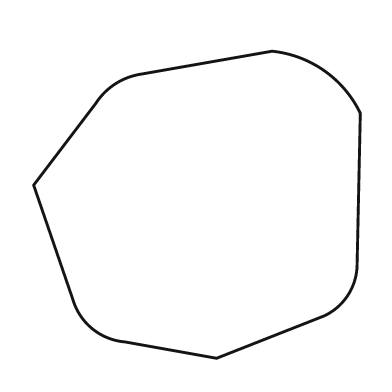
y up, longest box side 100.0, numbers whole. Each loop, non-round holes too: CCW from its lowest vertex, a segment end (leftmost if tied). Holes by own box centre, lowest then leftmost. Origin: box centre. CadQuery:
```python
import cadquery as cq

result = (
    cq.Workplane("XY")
    .moveTo(6.0, -47.0)
    .lineTo(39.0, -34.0)
    .threePointArc((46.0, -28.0), (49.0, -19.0))
    .lineTo(50.0, 28.0)
    .threePointArc((39.0, 41.0), (23.0, 47.0))
    .lineTo(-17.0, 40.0)
    .threePointArc((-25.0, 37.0), (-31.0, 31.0))
    .lineTo(-50.0, 6.0)
    .lineTo(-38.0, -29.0)
    .threePointArc((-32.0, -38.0), (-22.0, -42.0))
    .close()
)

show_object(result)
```